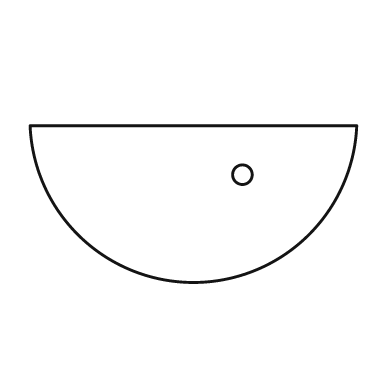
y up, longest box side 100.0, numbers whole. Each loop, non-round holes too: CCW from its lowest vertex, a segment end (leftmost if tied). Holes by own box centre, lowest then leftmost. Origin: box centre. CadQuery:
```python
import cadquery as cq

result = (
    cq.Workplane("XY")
    .moveTo(-50.0, 24.0)
    .threePointArc((0.0, -24.0), (50.0, 24.0))
    .close()
    .moveTo(15.0, 9.0)
    .circle(3.0)
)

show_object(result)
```